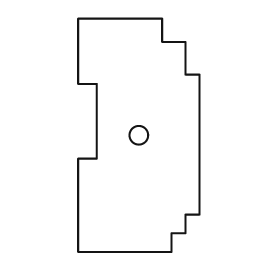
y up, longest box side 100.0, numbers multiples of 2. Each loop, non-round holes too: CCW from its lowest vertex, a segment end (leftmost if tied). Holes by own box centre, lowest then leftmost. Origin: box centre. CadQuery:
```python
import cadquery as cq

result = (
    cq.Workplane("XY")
    .moveTo(-26.0, -50.0)
    .lineTo(14.0, -50.0)
    .lineTo(14.0, -42.0)
    .lineTo(20.0, -42.0)
    .lineTo(20.0, -34.0)
    .lineTo(26.0, -34.0)
    .lineTo(26.0, 26.0)
    .lineTo(20.0, 26.0)
    .lineTo(20.0, 40.0)
    .lineTo(10.0, 40.0)
    .lineTo(10.0, 50.0)
    .lineTo(-26.0, 50.0)
    .lineTo(-26.0, 22.0)
    .lineTo(-18.0, 22.0)
    .lineTo(-18.0, -10.0)
    .lineTo(-26.0, -10.0)
    .close()
    .moveTo(0.0, 0.0)
    .circle(4.0)
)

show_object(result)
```